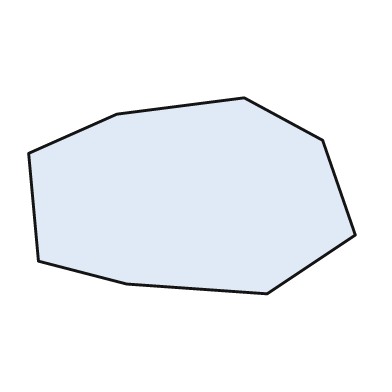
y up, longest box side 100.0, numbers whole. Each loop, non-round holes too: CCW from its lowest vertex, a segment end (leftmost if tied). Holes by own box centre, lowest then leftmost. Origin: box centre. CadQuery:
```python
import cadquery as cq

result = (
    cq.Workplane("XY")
    .moveTo(23.0, -30.0)
    .lineTo(50.0, -12.0)
    .lineTo(40.0, 17.0)
    .lineTo(16.0, 30.0)
    .lineTo(-23.0, 25.0)
    .lineTo(-50.0, 13.0)
    .lineTo(-47.0, -20.0)
    .lineTo(-20.0, -27.0)
    .close()
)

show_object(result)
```